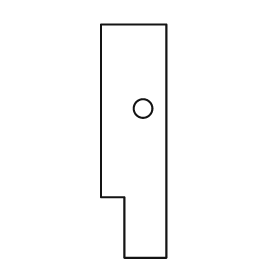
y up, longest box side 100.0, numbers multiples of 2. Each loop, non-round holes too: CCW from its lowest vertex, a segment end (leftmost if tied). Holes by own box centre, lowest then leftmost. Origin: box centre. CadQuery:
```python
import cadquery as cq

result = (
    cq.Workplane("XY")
    .moveTo(-4.0, -50.0)
    .lineTo(14.0, -50.0)
    .lineTo(14.0, 50.0)
    .lineTo(-14.0, 50.0)
    .lineTo(-14.0, -24.0)
    .lineTo(-4.0, -24.0)
    .close()
    .moveTo(4.0, 14.0)
    .circle(4.0)
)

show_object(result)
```